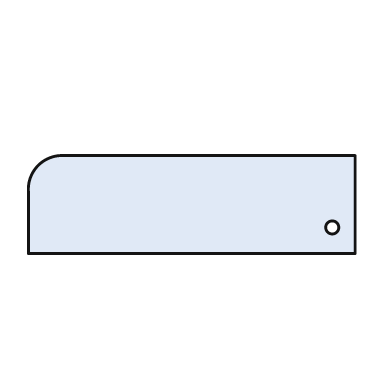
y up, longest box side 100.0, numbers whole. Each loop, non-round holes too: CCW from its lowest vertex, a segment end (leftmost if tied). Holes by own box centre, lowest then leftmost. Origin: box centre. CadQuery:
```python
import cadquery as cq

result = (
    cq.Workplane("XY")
    .moveTo(-50.0, -15.0)
    .lineTo(50.0, -15.0)
    .lineTo(50.0, 15.0)
    .lineTo(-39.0, 15.0)
    .threePointArc((-47.0, 12.0), (-50.0, 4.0))
    .close()
    .moveTo(43.0, -7.0)
    .circle(2.0)
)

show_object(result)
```